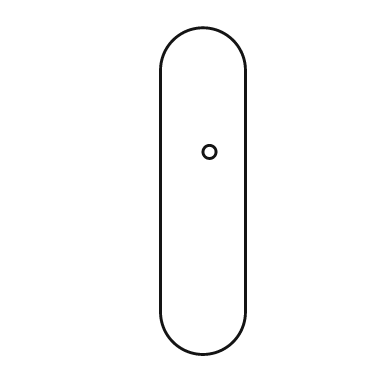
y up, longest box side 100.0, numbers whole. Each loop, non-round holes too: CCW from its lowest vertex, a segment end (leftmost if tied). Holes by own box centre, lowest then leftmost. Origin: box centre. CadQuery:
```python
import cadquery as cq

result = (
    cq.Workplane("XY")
    .moveTo(-13.0, -37.0)
    .threePointArc((0.0, -50.0), (13.0, -37.0))
    .lineTo(13.0, 37.0)
    .threePointArc((0.0, 50.0), (-13.0, 37.0))
    .close()
    .moveTo(2.0, 12.0)
    .circle(2.0)
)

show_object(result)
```